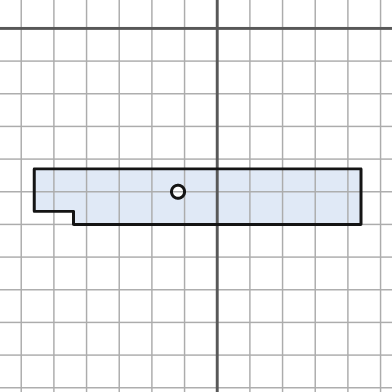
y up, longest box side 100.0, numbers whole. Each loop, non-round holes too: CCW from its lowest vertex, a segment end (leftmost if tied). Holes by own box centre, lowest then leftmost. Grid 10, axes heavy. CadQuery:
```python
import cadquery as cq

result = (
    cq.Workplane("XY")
    .moveTo(-44.0, -60.0)
    .lineTo(44.0, -60.0)
    .lineTo(44.0, -43.0)
    .lineTo(-56.0, -43.0)
    .lineTo(-56.0, -56.0)
    .lineTo(-44.0, -56.0)
    .close()
    .moveTo(-12.0, -50.0)
    .circle(2.0)
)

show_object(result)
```